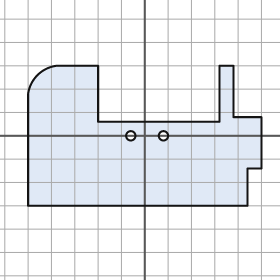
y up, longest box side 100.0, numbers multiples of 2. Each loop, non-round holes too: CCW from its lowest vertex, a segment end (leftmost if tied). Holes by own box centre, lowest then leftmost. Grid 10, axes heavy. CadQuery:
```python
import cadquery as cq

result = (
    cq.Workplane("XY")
    .moveTo(-50.0, -30.0)
    .lineTo(44.0, -30.0)
    .lineTo(44.0, -14.0)
    .lineTo(50.0, -14.0)
    .lineTo(50.0, 8.0)
    .lineTo(38.0, 8.0)
    .lineTo(38.0, 30.0)
    .lineTo(32.0, 30.0)
    .lineTo(32.0, 6.0)
    .lineTo(-20.0, 6.0)
    .lineTo(-20.0, 30.0)
    .lineTo(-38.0, 30.0)
    .threePointArc((-46.0, 26.0), (-50.0, 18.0))
    .close()
    .moveTo(-6.0, 0.0)
    .circle(2.0)
    .moveTo(8.0, 0.0)
    .circle(2.0)
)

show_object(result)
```